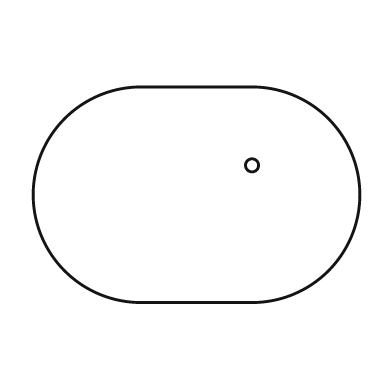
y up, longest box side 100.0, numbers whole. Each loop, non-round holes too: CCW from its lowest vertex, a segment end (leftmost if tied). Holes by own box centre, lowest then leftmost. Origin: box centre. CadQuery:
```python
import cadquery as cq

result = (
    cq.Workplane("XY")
    .moveTo(-17.0, -33.0)
    .lineTo(17.0, -33.0)
    .threePointArc((50.0, 0.0), (17.0, 33.0))
    .lineTo(-17.0, 33.0)
    .threePointArc((-50.0, 0.0), (-17.0, -33.0))
    .close()
    .moveTo(17.0, 9.0)
    .circle(2.0)
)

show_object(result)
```